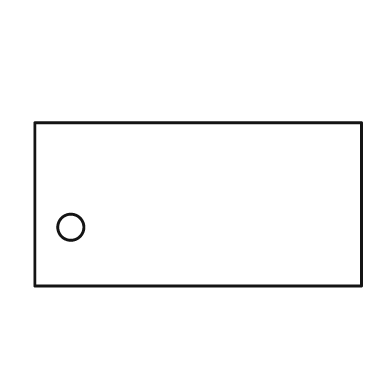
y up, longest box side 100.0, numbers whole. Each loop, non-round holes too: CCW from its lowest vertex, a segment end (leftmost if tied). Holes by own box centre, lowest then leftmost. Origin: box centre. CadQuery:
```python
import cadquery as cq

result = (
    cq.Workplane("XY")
    .moveTo(-50.0, -25.0)
    .lineTo(50.0, -25.0)
    .lineTo(50.0, 25.0)
    .lineTo(-50.0, 25.0)
    .close()
    .moveTo(-39.0, -7.0)
    .circle(4.0)
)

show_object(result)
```